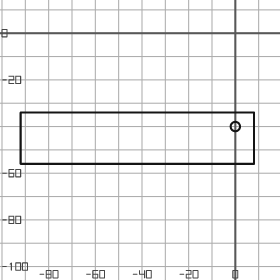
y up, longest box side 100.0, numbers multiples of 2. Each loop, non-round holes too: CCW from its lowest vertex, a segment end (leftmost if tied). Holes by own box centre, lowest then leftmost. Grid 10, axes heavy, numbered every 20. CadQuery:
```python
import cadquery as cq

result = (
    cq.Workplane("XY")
    .moveTo(-92.0, -56.0)
    .lineTo(8.0, -56.0)
    .lineTo(8.0, -34.0)
    .lineTo(-92.0, -34.0)
    .close()
    .moveTo(0.0, -40.0)
    .circle(2.0)
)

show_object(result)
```